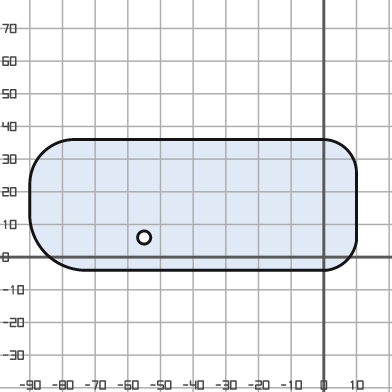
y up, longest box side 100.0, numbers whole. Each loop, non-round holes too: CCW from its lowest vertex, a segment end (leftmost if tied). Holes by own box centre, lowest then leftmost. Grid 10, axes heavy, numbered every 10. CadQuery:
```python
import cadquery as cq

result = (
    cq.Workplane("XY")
    .moveTo(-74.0, -4.0)
    .lineTo(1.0, -4.0)
    .threePointArc((7.0, -1.0), (10.0, 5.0))
    .lineTo(10.0, 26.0)
    .threePointArc((7.0, 33.0), (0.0, 36.0))
    .lineTo(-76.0, 36.0)
    .threePointArc((-86.0, 32.0), (-90.0, 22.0))
    .lineTo(-90.0, 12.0)
    .threePointArc((-85.0, 1.0), (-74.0, -4.0))
    .close()
    .moveTo(-55.0, 6.0)
    .circle(2.0)
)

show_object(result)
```